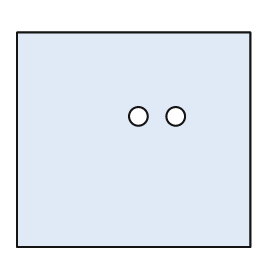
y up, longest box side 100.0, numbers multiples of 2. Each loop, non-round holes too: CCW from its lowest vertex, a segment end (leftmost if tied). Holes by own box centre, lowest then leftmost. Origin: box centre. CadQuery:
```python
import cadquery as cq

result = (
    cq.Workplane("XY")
    .moveTo(-50.0, -46.0)
    .lineTo(50.0, -46.0)
    .lineTo(50.0, 46.0)
    .lineTo(-50.0, 46.0)
    .close()
    .moveTo(2.0, 10.0)
    .circle(4.0)
    .moveTo(18.0, 10.0)
    .circle(4.0)
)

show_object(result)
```